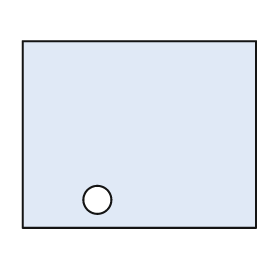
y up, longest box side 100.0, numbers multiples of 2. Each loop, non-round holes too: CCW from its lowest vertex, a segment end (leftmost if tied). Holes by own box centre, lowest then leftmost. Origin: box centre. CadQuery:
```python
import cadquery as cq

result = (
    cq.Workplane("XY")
    .moveTo(-50.0, -40.0)
    .lineTo(50.0, -40.0)
    .lineTo(50.0, 40.0)
    .lineTo(-50.0, 40.0)
    .close()
    .moveTo(-18.0, -28.0)
    .circle(6.0)
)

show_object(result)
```